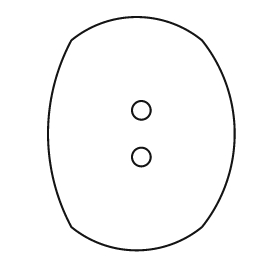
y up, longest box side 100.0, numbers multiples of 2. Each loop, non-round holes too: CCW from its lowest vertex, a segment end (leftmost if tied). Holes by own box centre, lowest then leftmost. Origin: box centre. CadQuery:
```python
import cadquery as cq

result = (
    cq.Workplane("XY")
    .moveTo(-30.0, -40.0)
    .threePointArc((-2.0, -50.0), (26.0, -40.0))
    .threePointArc((40.0, 0.0), (26.0, 40.0))
    .threePointArc((-2.0, 50.0), (-30.0, 40.0))
    .threePointArc((-40.0, 0.0), (-30.0, -40.0))
    .close()
    .moveTo(0.0, -10.0)
    .circle(4.0)
    .moveTo(0.0, 10.0)
    .circle(4.0)
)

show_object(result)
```